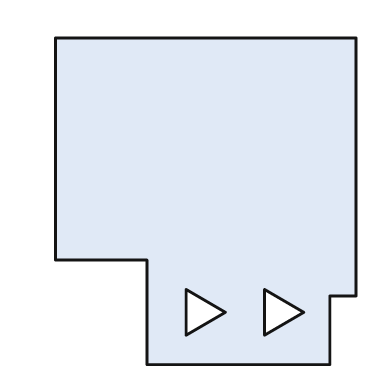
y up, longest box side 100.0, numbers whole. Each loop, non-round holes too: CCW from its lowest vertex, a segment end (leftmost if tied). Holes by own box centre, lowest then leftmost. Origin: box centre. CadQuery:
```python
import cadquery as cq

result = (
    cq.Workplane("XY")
    .moveTo(-18.0, -50.0)
    .lineTo(38.0, -50.0)
    .lineTo(38.0, -29.0)
    .lineTo(46.0, -29.0)
    .lineTo(46.0, 50.0)
    .lineTo(-46.0, 50.0)
    .lineTo(-46.0, -18.0)
    .lineTo(-18.0, -18.0)
    .close()
    .moveTo(-6.0, -41.0)
    .lineTo(6.0, -34.0)
    .lineTo(-6.0, -27.0)
    .close()
    .moveTo(18.0, -41.0)
    .lineTo(30.0, -34.0)
    .lineTo(18.0, -27.0)
    .close()
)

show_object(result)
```